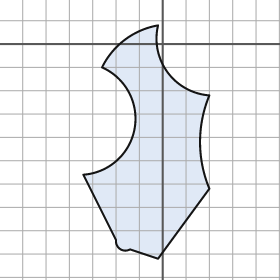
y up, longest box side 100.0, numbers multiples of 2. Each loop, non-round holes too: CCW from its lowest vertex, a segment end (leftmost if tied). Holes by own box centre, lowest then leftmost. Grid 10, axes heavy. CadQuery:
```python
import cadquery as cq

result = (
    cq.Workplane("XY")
    .moveTo(-2.0, -92.0)
    .lineTo(20.0, -62.0)
    .threePointArc((16.0, -42.0), (20.0, -22.0))
    .threePointArc((2.0, -12.0), (-2.0, 8.0))
    .threePointArc((-16.0, 2.0), (-26.0, -10.0))
    .threePointArc((-12.0, -36.0), (-34.0, -56.0))
    .lineTo(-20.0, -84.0)
    .threePointArc((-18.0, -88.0), (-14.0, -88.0))
    .close()
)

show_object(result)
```